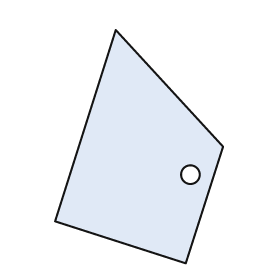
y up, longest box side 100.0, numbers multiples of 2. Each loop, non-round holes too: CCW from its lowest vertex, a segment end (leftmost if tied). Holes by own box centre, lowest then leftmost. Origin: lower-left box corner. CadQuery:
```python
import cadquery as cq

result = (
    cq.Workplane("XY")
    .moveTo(56.0, 0.0)
    .lineTo(72.0, 50.0)
    .lineTo(26.0, 100.0)
    .lineTo(0.0, 18.0)
    .close()
    .moveTo(58.0, 38.0)
    .circle(4.0)
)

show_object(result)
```